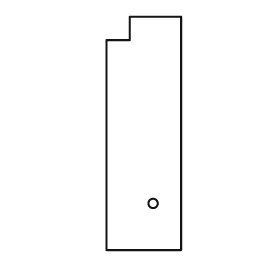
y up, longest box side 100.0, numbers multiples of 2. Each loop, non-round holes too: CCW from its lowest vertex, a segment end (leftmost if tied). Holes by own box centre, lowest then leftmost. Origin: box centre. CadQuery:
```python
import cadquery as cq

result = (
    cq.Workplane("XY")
    .moveTo(-16.0, -50.0)
    .lineTo(16.0, -50.0)
    .lineTo(16.0, 50.0)
    .lineTo(-6.0, 50.0)
    .lineTo(-6.0, 40.0)
    .lineTo(-16.0, 40.0)
    .close()
    .moveTo(4.0, -30.0)
    .circle(2.0)
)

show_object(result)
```